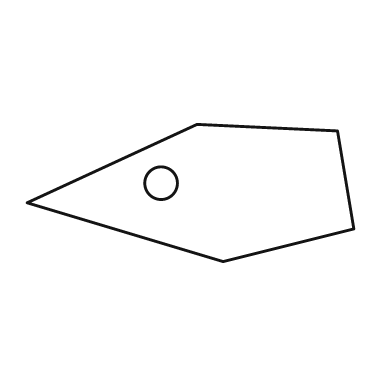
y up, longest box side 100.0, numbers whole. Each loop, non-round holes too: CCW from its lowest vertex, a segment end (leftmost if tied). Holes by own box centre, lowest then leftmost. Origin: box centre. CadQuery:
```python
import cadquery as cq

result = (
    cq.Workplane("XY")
    .moveTo(10.0, -21.0)
    .lineTo(50.0, -11.0)
    .lineTo(45.0, 19.0)
    .lineTo(2.0, 21.0)
    .lineTo(-50.0, -3.0)
    .close()
    .moveTo(-9.0, 3.0)
    .circle(5.0)
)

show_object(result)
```